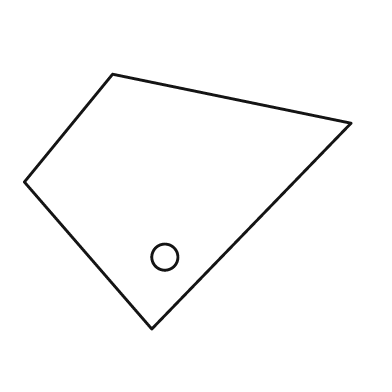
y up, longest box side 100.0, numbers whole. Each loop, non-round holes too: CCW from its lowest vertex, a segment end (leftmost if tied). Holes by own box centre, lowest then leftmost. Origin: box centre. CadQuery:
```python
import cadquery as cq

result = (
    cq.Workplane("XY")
    .moveTo(-11.0, -39.0)
    .lineTo(50.0, 24.0)
    .lineTo(-23.0, 39.0)
    .lineTo(-50.0, 6.0)
    .close()
    .moveTo(-7.0, -17.0)
    .circle(4.0)
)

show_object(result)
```